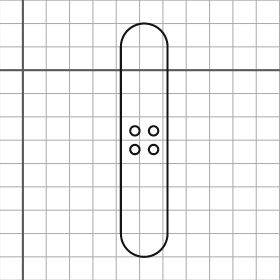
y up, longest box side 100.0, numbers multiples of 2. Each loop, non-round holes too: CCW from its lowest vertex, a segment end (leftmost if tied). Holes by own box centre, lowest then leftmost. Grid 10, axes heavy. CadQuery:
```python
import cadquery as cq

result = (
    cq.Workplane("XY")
    .moveTo(42.0, -70.0)
    .threePointArc((52.0, -80.0), (62.0, -70.0))
    .lineTo(62.0, 10.0)
    .threePointArc((52.0, 20.0), (42.0, 10.0))
    .close()
    .moveTo(48.0, -34.0)
    .circle(2.0)
    .moveTo(56.0, -34.0)
    .circle(2.0)
    .moveTo(48.0, -26.0)
    .circle(2.0)
    .moveTo(56.0, -26.0)
    .circle(2.0)
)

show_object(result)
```